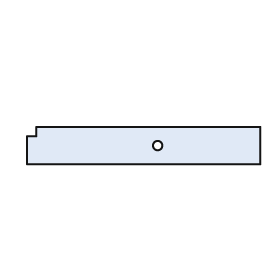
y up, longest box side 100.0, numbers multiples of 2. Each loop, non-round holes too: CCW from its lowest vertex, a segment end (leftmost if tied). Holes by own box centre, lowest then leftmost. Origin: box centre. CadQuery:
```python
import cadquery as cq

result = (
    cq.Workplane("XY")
    .moveTo(-50.0, -8.0)
    .lineTo(50.0, -8.0)
    .lineTo(50.0, 8.0)
    .lineTo(-46.0, 8.0)
    .lineTo(-46.0, 4.0)
    .lineTo(-50.0, 4.0)
    .close()
    .moveTo(6.0, 0.0)
    .circle(2.0)
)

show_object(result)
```